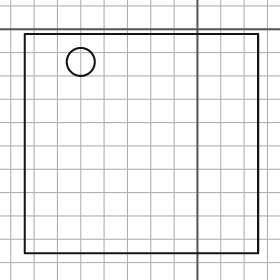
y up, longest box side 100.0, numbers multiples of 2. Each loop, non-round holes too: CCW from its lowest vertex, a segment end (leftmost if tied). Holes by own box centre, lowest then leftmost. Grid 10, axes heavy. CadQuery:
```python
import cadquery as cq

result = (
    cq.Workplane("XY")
    .moveTo(-74.0, -96.0)
    .lineTo(26.0, -96.0)
    .lineTo(26.0, -2.0)
    .lineTo(-74.0, -2.0)
    .close()
    .moveTo(-50.0, -14.0)
    .circle(6.0)
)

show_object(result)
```